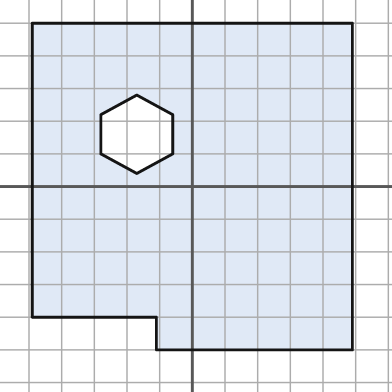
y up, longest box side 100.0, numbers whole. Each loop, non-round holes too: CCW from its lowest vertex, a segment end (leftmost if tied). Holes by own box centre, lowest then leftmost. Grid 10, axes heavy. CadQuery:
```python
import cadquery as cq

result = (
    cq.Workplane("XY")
    .moveTo(-11.0, -50.0)
    .lineTo(49.0, -50.0)
    .lineTo(49.0, 50.0)
    .lineTo(-49.0, 50.0)
    .lineTo(-49.0, -40.0)
    .lineTo(-11.0, -40.0)
    .close()
    .moveTo(-17.0, 4.0)
    .lineTo(-6.0, 10.0)
    .lineTo(-6.0, 22.0)
    .lineTo(-17.0, 28.0)
    .lineTo(-28.0, 22.0)
    .lineTo(-28.0, 10.0)
    .close()
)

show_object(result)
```